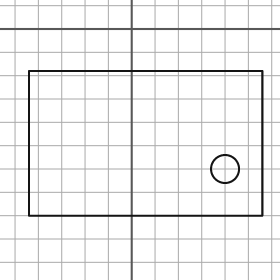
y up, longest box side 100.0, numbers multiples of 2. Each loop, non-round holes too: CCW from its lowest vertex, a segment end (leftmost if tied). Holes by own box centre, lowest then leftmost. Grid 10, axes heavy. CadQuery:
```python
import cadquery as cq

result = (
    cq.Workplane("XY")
    .moveTo(-44.0, -80.0)
    .lineTo(56.0, -80.0)
    .lineTo(56.0, -18.0)
    .lineTo(-44.0, -18.0)
    .close()
    .moveTo(40.0, -60.0)
    .circle(6.0)
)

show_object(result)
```